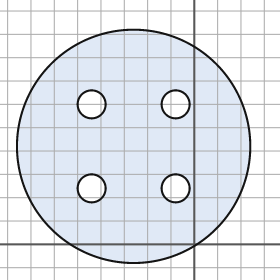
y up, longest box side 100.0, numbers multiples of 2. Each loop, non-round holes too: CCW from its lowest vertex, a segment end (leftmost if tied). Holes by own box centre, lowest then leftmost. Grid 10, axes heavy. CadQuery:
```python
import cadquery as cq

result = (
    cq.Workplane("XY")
    .moveTo(-26.0, 42.0)
    .circle(50.0)
    .moveTo(-44.0, 24.0)
    .circle(6.0)
    .moveTo(-8.0, 24.0)
    .circle(6.0)
    .moveTo(-44.0, 60.0)
    .circle(6.0)
    .moveTo(-8.0, 60.0)
    .circle(6.0)
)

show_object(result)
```